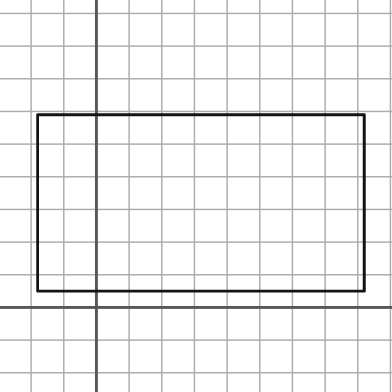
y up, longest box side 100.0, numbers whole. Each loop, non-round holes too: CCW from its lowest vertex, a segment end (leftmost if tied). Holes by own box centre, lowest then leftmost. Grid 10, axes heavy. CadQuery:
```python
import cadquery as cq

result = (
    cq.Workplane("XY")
    .moveTo(-18.0, 5.0)
    .lineTo(82.0, 5.0)
    .lineTo(82.0, 59.0)
    .lineTo(-18.0, 59.0)
    .close()
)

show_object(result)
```